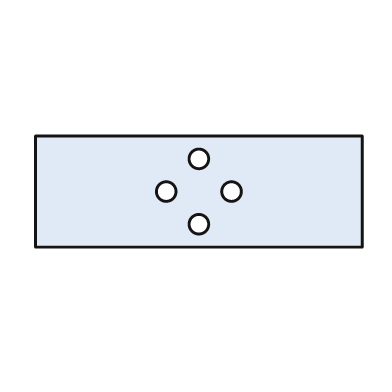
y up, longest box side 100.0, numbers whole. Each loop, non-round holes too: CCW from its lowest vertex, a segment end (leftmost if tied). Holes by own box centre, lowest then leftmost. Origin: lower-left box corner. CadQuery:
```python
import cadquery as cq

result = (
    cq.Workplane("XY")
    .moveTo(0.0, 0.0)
    .lineTo(100.0, 0.0)
    .lineTo(100.0, 34.0)
    .lineTo(0.0, 34.0)
    .close()
    .moveTo(50.0, 7.0)
    .circle(3.0)
    .moveTo(40.0, 17.0)
    .circle(3.0)
    .moveTo(60.0, 17.0)
    .circle(3.0)
    .moveTo(50.0, 27.0)
    .circle(3.0)
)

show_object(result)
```